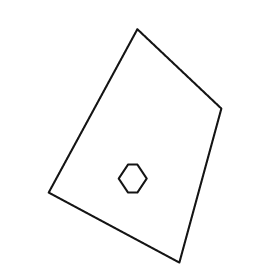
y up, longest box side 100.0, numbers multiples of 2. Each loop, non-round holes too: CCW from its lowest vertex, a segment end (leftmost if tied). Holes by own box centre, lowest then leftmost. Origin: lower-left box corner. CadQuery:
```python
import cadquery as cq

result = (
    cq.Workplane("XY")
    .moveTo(56.0, 0.0)
    .lineTo(74.0, 66.0)
    .lineTo(38.0, 100.0)
    .lineTo(0.0, 30.0)
    .close()
    .moveTo(34.0, 30.0)
    .lineTo(38.0, 30.0)
    .lineTo(42.0, 36.0)
    .lineTo(38.0, 42.0)
    .lineTo(34.0, 42.0)
    .lineTo(30.0, 36.0)
    .close()
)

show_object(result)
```